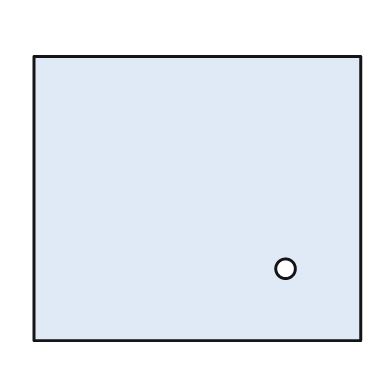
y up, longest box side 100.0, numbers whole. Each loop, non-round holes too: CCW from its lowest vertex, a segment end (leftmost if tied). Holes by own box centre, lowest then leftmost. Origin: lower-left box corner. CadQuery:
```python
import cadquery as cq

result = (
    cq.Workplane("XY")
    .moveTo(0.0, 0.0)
    .lineTo(100.0, 0.0)
    .lineTo(100.0, 87.0)
    .lineTo(0.0, 87.0)
    .close()
    .moveTo(77.0, 22.0)
    .circle(3.0)
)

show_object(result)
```